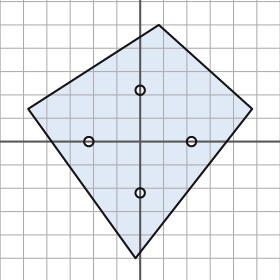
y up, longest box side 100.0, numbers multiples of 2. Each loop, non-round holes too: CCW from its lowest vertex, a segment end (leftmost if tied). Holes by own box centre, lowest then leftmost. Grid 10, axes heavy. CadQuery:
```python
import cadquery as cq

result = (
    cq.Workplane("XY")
    .moveTo(-2.0, -50.0)
    .lineTo(48.0, 14.0)
    .lineTo(8.0, 50.0)
    .lineTo(-48.0, 14.0)
    .close()
    .moveTo(0.0, -22.0)
    .circle(2.0)
    .moveTo(-22.0, 0.0)
    .circle(2.0)
    .moveTo(22.0, 0.0)
    .circle(2.0)
    .moveTo(0.0, 22.0)
    .circle(2.0)
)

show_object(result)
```